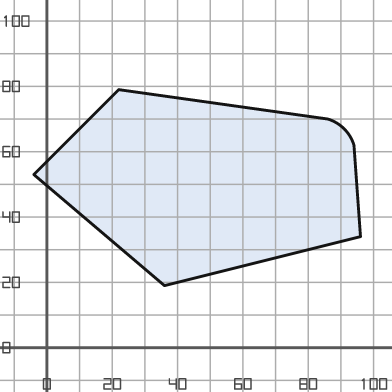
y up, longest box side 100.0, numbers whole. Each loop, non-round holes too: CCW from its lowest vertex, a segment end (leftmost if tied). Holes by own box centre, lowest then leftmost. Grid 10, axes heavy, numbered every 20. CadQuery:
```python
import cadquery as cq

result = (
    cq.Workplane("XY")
    .moveTo(36.0, 19.0)
    .lineTo(96.0, 34.0)
    .lineTo(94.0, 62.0)
    .threePointArc((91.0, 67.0), (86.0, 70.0))
    .lineTo(22.0, 79.0)
    .lineTo(-4.0, 53.0)
    .close()
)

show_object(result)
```